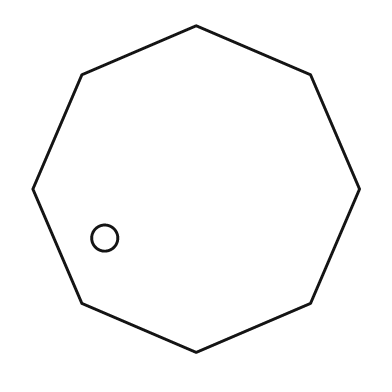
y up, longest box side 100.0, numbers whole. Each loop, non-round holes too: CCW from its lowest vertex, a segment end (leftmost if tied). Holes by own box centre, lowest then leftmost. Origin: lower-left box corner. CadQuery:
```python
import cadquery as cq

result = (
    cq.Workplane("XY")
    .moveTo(50.0, 0.0)
    .lineTo(85.0, 15.0)
    .lineTo(100.0, 50.0)
    .lineTo(85.0, 85.0)
    .lineTo(50.0, 100.0)
    .lineTo(15.0, 85.0)
    .lineTo(0.0, 50.0)
    .lineTo(15.0, 15.0)
    .close()
    .moveTo(22.0, 35.0)
    .circle(4.0)
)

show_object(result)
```